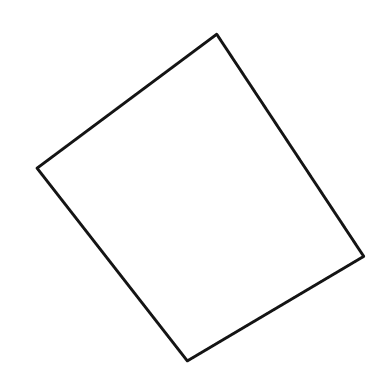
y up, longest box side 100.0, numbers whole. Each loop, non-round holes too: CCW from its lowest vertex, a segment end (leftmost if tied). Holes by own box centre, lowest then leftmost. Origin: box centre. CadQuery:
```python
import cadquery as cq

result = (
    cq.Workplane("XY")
    .moveTo(-4.0, -50.0)
    .lineTo(50.0, -18.0)
    .lineTo(5.0, 50.0)
    .lineTo(-50.0, 9.0)
    .close()
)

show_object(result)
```